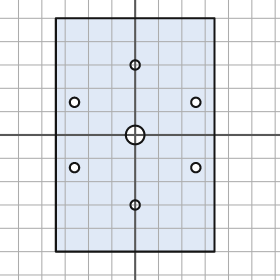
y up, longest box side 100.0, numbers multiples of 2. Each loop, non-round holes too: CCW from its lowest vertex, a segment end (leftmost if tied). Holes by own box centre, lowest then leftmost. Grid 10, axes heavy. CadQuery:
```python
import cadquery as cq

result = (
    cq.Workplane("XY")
    .moveTo(-34.0, -50.0)
    .lineTo(34.0, -50.0)
    .lineTo(34.0, 50.0)
    .lineTo(-34.0, 50.0)
    .close()
    .moveTo(0.0, -30.0)
    .circle(2.0)
    .moveTo(-26.0, -14.0)
    .circle(2.0)
    .moveTo(26.0, -14.0)
    .circle(2.0)
    .moveTo(0.0, 0.0)
    .circle(4.0)
    .moveTo(-26.0, 14.0)
    .circle(2.0)
    .moveTo(26.0, 14.0)
    .circle(2.0)
    .moveTo(0.0, 30.0)
    .circle(2.0)
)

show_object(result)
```